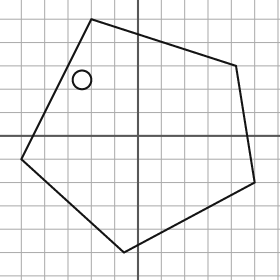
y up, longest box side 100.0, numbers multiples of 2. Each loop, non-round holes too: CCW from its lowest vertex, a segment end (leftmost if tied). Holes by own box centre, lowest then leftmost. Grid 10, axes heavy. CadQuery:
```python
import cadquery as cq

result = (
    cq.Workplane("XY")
    .moveTo(-6.0, -50.0)
    .lineTo(50.0, -20.0)
    .lineTo(42.0, 30.0)
    .lineTo(-20.0, 50.0)
    .lineTo(-50.0, -10.0)
    .close()
    .moveTo(-24.0, 24.0)
    .circle(4.0)
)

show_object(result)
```